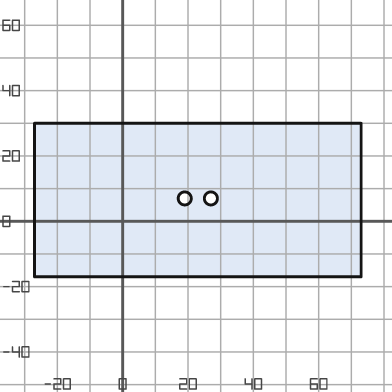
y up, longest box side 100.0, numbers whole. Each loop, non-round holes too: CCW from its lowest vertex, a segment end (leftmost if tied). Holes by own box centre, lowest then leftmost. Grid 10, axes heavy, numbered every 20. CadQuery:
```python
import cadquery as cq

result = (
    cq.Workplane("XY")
    .moveTo(-27.0, -17.0)
    .lineTo(73.0, -17.0)
    .lineTo(73.0, 30.0)
    .lineTo(-27.0, 30.0)
    .close()
    .moveTo(19.0, 7.0)
    .circle(2.0)
    .moveTo(27.0, 7.0)
    .circle(2.0)
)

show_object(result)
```